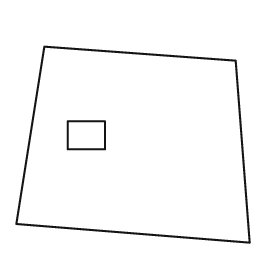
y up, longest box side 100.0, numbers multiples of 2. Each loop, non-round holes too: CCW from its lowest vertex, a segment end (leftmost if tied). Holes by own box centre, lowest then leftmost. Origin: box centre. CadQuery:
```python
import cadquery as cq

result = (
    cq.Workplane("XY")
    .moveTo(50.0, -42.0)
    .lineTo(44.0, 36.0)
    .lineTo(-38.0, 42.0)
    .lineTo(-50.0, -34.0)
    .close()
    .moveTo(-28.0, -2.0)
    .lineTo(-12.0, -2.0)
    .lineTo(-12.0, 10.0)
    .lineTo(-28.0, 10.0)
    .close()
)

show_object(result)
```